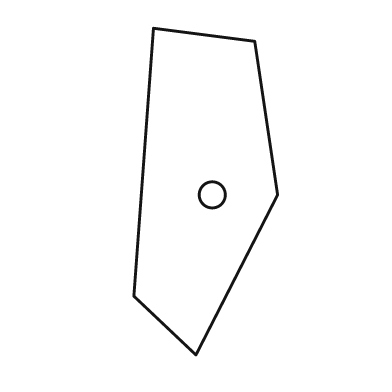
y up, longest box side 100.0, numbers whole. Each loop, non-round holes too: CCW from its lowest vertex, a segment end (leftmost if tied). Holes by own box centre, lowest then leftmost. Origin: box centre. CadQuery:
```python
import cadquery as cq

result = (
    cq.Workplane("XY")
    .moveTo(-3.0, -50.0)
    .lineTo(22.0, -1.0)
    .lineTo(15.0, 46.0)
    .lineTo(-16.0, 50.0)
    .lineTo(-22.0, -32.0)
    .close()
    .moveTo(2.0, -1.0)
    .circle(4.0)
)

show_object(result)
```